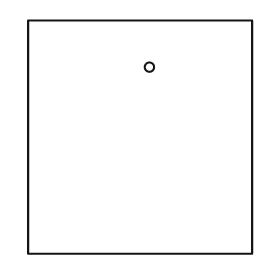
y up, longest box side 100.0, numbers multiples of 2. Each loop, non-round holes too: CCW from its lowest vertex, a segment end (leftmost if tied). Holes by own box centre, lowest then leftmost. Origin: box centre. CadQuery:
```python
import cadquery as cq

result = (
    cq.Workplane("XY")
    .moveTo(-48.0, -50.0)
    .lineTo(48.0, -50.0)
    .lineTo(48.0, 50.0)
    .lineTo(-48.0, 50.0)
    .close()
    .moveTo(4.0, 30.0)
    .circle(2.0)
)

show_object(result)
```